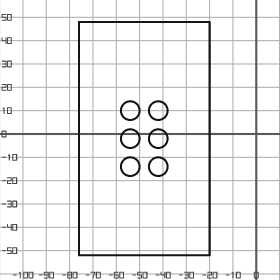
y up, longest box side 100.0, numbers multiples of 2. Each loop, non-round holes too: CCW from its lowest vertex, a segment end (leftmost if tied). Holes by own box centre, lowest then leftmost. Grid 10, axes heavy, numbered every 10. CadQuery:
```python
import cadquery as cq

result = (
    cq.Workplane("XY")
    .moveTo(-76.0, -52.0)
    .lineTo(-20.0, -52.0)
    .lineTo(-20.0, 48.0)
    .lineTo(-76.0, 48.0)
    .close()
    .moveTo(-54.0, -14.0)
    .circle(4.0)
    .moveTo(-42.0, -14.0)
    .circle(4.0)
    .moveTo(-54.0, -2.0)
    .circle(4.0)
    .moveTo(-42.0, -2.0)
    .circle(4.0)
    .moveTo(-54.0, 10.0)
    .circle(4.0)
    .moveTo(-42.0, 10.0)
    .circle(4.0)
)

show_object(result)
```